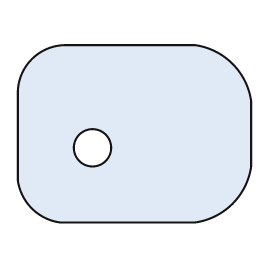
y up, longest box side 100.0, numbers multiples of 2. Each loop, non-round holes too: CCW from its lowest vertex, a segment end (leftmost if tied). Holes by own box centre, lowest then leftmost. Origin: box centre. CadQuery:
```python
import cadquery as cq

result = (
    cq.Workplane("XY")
    .moveTo(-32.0, -38.0)
    .lineTo(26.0, -38.0)
    .threePointArc((42.0, -30.0), (50.0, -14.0))
    .lineTo(50.0, 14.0)
    .threePointArc((42.0, 30.0), (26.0, 38.0))
    .lineTo(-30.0, 38.0)
    .threePointArc((-44.0, 32.0), (-50.0, 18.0))
    .lineTo(-50.0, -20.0)
    .threePointArc((-44.0, -32.0), (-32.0, -38.0))
    .close()
    .moveTo(-18.0, -6.0)
    .circle(8.0)
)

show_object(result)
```